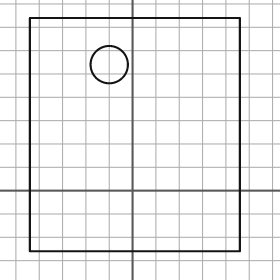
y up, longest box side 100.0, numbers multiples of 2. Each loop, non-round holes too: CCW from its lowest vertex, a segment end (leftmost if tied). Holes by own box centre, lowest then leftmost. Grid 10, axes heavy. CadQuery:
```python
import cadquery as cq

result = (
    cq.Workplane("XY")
    .moveTo(-44.0, -26.0)
    .lineTo(46.0, -26.0)
    .lineTo(46.0, 74.0)
    .lineTo(-44.0, 74.0)
    .close()
    .moveTo(-10.0, 54.0)
    .circle(8.0)
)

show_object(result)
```